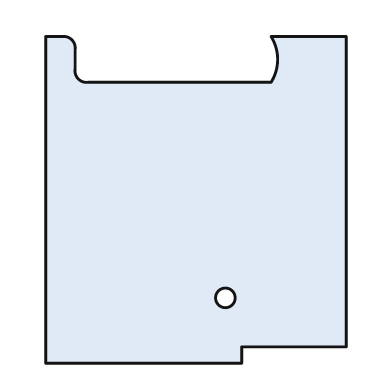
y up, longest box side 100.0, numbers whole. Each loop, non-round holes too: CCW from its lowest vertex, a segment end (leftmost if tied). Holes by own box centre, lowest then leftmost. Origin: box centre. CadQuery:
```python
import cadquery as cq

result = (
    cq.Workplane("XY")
    .moveTo(-46.0, -50.0)
    .lineTo(14.0, -50.0)
    .lineTo(14.0, -45.0)
    .lineTo(46.0, -45.0)
    .lineTo(46.0, 50.0)
    .lineTo(23.0, 50.0)
    .threePointArc((25.0, 43.0), (23.0, 36.0))
    .lineTo(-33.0, 36.0)
    .threePointArc((-36.0, 37.0), (-37.0, 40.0))
    .lineTo(-37.0, 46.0)
    .threePointArc((-38.0, 49.0), (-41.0, 50.0))
    .lineTo(-46.0, 50.0)
    .close()
    .moveTo(9.0, -30.0)
    .circle(3.0)
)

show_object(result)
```